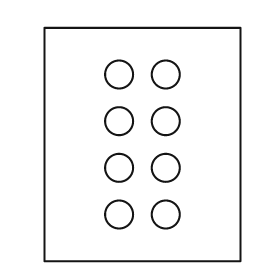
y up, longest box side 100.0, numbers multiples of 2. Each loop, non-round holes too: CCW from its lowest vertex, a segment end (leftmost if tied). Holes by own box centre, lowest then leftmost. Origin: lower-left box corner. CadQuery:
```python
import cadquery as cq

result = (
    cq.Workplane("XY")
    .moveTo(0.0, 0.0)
    .lineTo(84.0, 0.0)
    .lineTo(84.0, 100.0)
    .lineTo(0.0, 100.0)
    .close()
    .moveTo(32.0, 20.0)
    .circle(6.0)
    .moveTo(52.0, 20.0)
    .circle(6.0)
    .moveTo(32.0, 40.0)
    .circle(6.0)
    .moveTo(52.0, 40.0)
    .circle(6.0)
    .moveTo(32.0, 60.0)
    .circle(6.0)
    .moveTo(52.0, 60.0)
    .circle(6.0)
    .moveTo(32.0, 80.0)
    .circle(6.0)
    .moveTo(52.0, 80.0)
    .circle(6.0)
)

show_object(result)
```